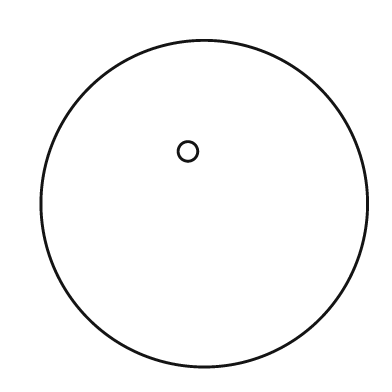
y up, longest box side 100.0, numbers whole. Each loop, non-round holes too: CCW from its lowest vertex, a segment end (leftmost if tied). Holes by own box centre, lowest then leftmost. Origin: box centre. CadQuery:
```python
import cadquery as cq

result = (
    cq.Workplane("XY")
    .moveTo(0.0, 0.0)
    .circle(50.0)
    .moveTo(-5.0, 16.0)
    .circle(3.0)
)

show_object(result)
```